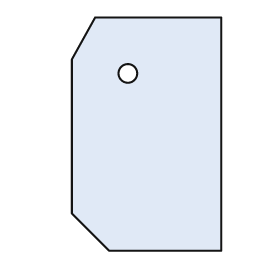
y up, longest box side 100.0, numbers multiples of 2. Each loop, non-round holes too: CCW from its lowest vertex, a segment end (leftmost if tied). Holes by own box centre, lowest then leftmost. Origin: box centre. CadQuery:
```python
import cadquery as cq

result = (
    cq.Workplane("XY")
    .moveTo(-16.0, -50.0)
    .lineTo(32.0, -50.0)
    .lineTo(32.0, 50.0)
    .lineTo(-22.0, 50.0)
    .lineTo(-32.0, 32.0)
    .lineTo(-32.0, -34.0)
    .close()
    .moveTo(-8.0, 26.0)
    .circle(4.0)
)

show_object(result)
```